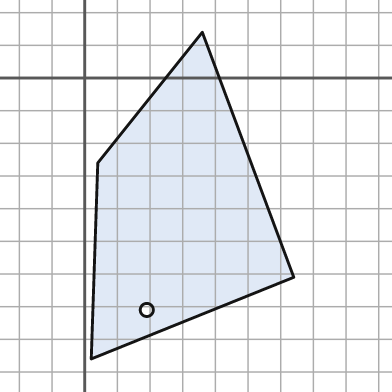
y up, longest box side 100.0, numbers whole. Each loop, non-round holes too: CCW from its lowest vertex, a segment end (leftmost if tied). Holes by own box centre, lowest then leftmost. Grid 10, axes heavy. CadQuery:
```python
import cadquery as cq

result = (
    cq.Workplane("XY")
    .moveTo(2.0, -86.0)
    .lineTo(64.0, -61.0)
    .lineTo(36.0, 14.0)
    .lineTo(4.0, -26.0)
    .close()
    .moveTo(19.0, -71.0)
    .circle(2.0)
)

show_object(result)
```